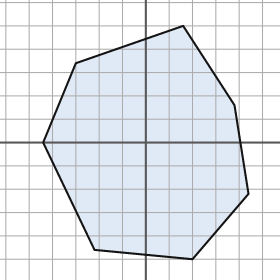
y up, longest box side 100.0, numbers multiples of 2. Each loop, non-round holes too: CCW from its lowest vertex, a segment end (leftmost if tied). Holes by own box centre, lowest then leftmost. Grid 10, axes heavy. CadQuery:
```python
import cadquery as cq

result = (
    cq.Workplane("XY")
    .moveTo(20.0, -50.0)
    .lineTo(44.0, -22.0)
    .lineTo(38.0, 16.0)
    .lineTo(16.0, 50.0)
    .lineTo(-30.0, 34.0)
    .lineTo(-44.0, 0.0)
    .lineTo(-22.0, -46.0)
    .close()
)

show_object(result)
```